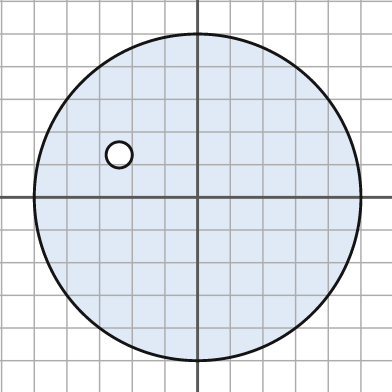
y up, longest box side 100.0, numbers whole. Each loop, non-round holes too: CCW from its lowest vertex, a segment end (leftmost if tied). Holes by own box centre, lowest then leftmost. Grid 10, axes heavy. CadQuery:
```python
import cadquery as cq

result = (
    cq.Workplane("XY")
    .moveTo(0.0, 0.0)
    .circle(50.0)
    .moveTo(-24.0, 13.0)
    .circle(4.0)
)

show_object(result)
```